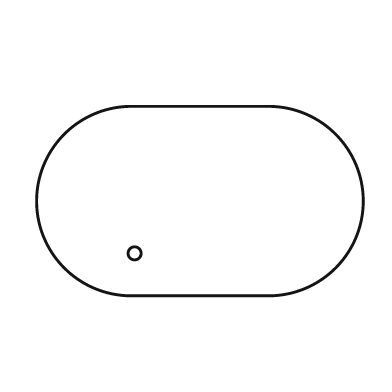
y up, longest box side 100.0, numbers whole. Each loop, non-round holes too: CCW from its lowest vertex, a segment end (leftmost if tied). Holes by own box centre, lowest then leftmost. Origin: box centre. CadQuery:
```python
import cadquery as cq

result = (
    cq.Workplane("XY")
    .moveTo(-21.0, -29.0)
    .lineTo(21.0, -29.0)
    .threePointArc((50.0, 0.0), (21.0, 29.0))
    .lineTo(-21.0, 29.0)
    .threePointArc((-50.0, 0.0), (-21.0, -29.0))
    .close()
    .moveTo(-20.0, -16.0)
    .circle(2.0)
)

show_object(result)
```